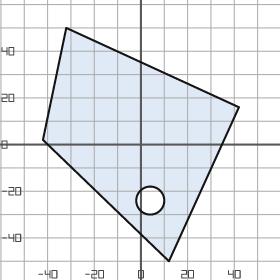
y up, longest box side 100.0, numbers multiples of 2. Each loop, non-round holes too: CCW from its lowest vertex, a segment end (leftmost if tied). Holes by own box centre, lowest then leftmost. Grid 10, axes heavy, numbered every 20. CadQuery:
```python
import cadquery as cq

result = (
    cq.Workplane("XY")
    .moveTo(12.0, -50.0)
    .lineTo(42.0, 16.0)
    .lineTo(-32.0, 50.0)
    .lineTo(-42.0, 2.0)
    .close()
    .moveTo(4.0, -24.0)
    .circle(6.0)
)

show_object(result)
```